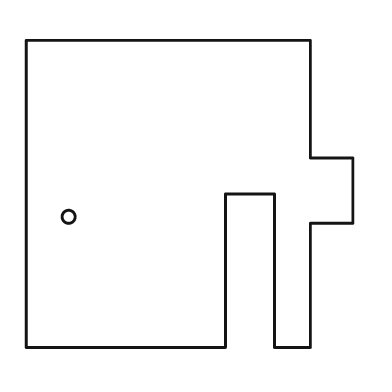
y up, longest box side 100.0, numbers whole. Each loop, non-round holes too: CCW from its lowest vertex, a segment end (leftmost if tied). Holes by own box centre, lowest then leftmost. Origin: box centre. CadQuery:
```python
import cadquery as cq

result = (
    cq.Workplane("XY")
    .moveTo(-50.0, -47.0)
    .lineTo(11.0, -47.0)
    .lineTo(11.0, 0.0)
    .lineTo(26.0, 0.0)
    .lineTo(26.0, -47.0)
    .lineTo(37.0, -47.0)
    .lineTo(37.0, -9.0)
    .lineTo(50.0, -9.0)
    .lineTo(50.0, 11.0)
    .lineTo(37.0, 11.0)
    .lineTo(37.0, 47.0)
    .lineTo(-50.0, 47.0)
    .close()
    .moveTo(-37.0, -7.0)
    .circle(2.0)
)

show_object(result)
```